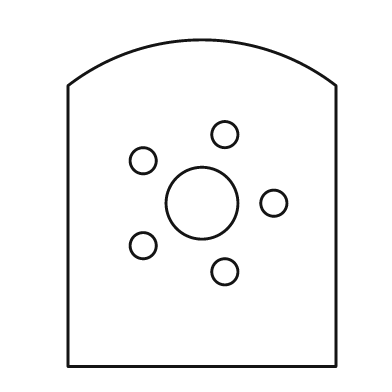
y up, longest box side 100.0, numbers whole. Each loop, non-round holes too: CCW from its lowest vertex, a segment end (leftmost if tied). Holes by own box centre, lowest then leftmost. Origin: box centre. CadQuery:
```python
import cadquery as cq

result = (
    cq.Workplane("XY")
    .moveTo(-41.0, -50.0)
    .lineTo(41.0, -50.0)
    .lineTo(41.0, 36.0)
    .threePointArc((0.0, 50.0), (-41.0, 36.0))
    .close()
    .moveTo(7.0, -21.0)
    .circle(4.0)
    .moveTo(-18.0, -13.0)
    .circle(4.0)
    .moveTo(0.0, 0.0)
    .circle(11.0)
    .moveTo(22.0, 0.0)
    .circle(4.0)
    .moveTo(-18.0, 13.0)
    .circle(4.0)
    .moveTo(7.0, 21.0)
    .circle(4.0)
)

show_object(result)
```